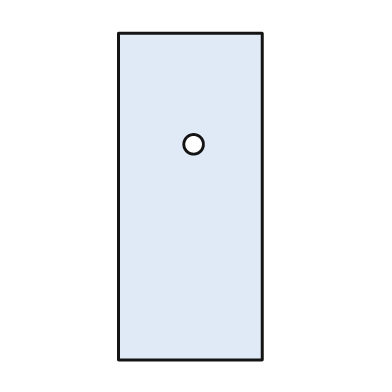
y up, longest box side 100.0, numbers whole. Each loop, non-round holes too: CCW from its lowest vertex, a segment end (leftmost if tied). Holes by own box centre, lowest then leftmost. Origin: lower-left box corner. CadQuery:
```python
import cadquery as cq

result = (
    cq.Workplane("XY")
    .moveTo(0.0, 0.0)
    .lineTo(44.0, 0.0)
    .lineTo(44.0, 100.0)
    .lineTo(0.0, 100.0)
    .close()
    .moveTo(23.0, 66.0)
    .circle(3.0)
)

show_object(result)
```